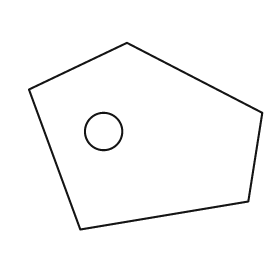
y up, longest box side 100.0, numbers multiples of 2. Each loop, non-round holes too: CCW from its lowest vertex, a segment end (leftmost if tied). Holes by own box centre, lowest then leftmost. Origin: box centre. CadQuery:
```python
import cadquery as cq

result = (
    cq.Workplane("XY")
    .moveTo(-28.0, -40.0)
    .lineTo(44.0, -28.0)
    .lineTo(50.0, 10.0)
    .lineTo(-8.0, 40.0)
    .lineTo(-50.0, 20.0)
    .close()
    .moveTo(-18.0, 2.0)
    .circle(8.0)
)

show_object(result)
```